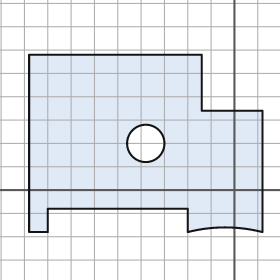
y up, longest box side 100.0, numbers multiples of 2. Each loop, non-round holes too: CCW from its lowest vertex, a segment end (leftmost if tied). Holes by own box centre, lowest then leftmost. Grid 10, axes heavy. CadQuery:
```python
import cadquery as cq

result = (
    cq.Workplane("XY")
    .moveTo(-88.0, -18.0)
    .lineTo(-80.0, -18.0)
    .lineTo(-80.0, -8.0)
    .lineTo(-20.0, -8.0)
    .lineTo(-20.0, -18.0)
    .threePointArc((-4.0, -16.0), (12.0, -18.0))
    .lineTo(12.0, 34.0)
    .lineTo(-14.0, 34.0)
    .lineTo(-14.0, 58.0)
    .lineTo(-88.0, 58.0)
    .close()
    .moveTo(-38.0, 20.0)
    .circle(8.0)
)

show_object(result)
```